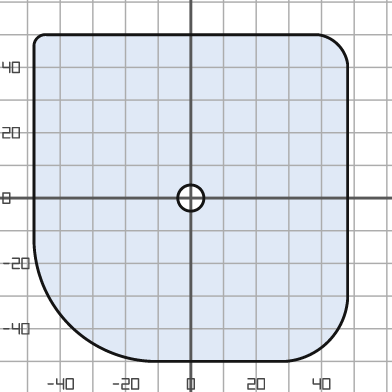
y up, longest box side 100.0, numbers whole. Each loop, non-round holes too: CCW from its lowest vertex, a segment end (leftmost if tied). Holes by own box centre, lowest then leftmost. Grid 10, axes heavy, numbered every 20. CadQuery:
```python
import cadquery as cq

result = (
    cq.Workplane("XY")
    .moveTo(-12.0, -50.0)
    .lineTo(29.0, -50.0)
    .threePointArc((42.0, -44.0), (48.0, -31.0))
    .lineTo(48.0, 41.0)
    .threePointArc((45.0, 47.0), (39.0, 50.0))
    .lineTo(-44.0, 50.0)
    .threePointArc((-47.0, 49.0), (-48.0, 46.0))
    .lineTo(-48.0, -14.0)
    .threePointArc((-37.0, -39.0), (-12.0, -50.0))
    .close()
    .moveTo(0.0, 0.0)
    .circle(4.0)
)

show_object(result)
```